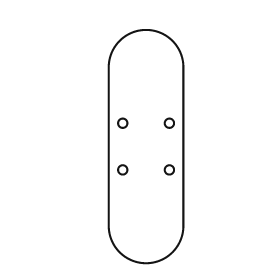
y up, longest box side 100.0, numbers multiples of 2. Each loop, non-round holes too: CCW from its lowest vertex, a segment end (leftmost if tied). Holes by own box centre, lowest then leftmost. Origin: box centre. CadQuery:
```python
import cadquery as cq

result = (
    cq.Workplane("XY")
    .moveTo(-16.0, -34.0)
    .threePointArc((0.0, -50.0), (16.0, -34.0))
    .lineTo(16.0, 34.0)
    .threePointArc((0.0, 50.0), (-16.0, 34.0))
    .close()
    .moveTo(-10.0, -10.0)
    .circle(2.0)
    .moveTo(10.0, -10.0)
    .circle(2.0)
    .moveTo(-10.0, 10.0)
    .circle(2.0)
    .moveTo(10.0, 10.0)
    .circle(2.0)
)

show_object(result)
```